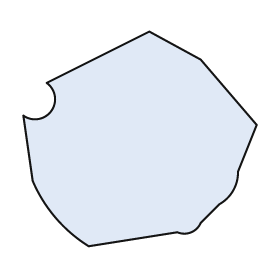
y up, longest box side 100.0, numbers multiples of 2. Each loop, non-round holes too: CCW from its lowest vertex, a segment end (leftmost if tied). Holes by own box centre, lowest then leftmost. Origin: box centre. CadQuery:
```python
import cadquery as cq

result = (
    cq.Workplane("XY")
    .moveTo(-22.0, -46.0)
    .lineTo(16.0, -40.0)
    .threePointArc((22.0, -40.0), (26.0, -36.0))
    .lineTo(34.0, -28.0)
    .threePointArc((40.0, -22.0), (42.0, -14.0))
    .lineTo(50.0, 6.0)
    .lineTo(26.0, 34.0)
    .lineTo(4.0, 46.0)
    .lineTo(-40.0, 24.0)
    .threePointArc((-38.0, 12.0), (-50.0, 10.0))
    .lineTo(-46.0, -18.0)
    .threePointArc((-36.0, -34.0), (-22.0, -46.0))
    .close()
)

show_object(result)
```